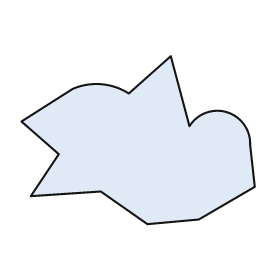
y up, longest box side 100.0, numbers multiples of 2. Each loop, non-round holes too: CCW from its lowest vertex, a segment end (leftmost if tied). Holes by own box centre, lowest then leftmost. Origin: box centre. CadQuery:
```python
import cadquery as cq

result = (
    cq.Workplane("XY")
    .moveTo(4.0, -36.0)
    .lineTo(26.0, -34.0)
    .lineTo(50.0, -20.0)
    .lineTo(48.0, -2.0)
    .threePointArc((38.0, 12.0), (22.0, 6.0))
    .lineTo(14.0, 36.0)
    .lineTo(-4.0, 20.0)
    .threePointArc((-16.0, 24.0), (-28.0, 22.0))
    .lineTo(-50.0, 8.0)
    .lineTo(-34.0, -6.0)
    .lineTo(-46.0, -24.0)
    .lineTo(-16.0, -22.0)
    .close()
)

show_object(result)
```